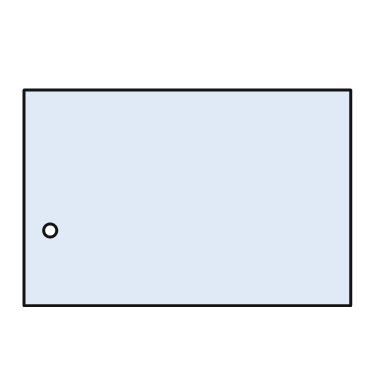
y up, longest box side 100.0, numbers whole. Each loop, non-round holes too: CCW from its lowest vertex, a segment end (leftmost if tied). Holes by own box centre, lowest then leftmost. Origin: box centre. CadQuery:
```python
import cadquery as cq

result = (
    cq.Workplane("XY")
    .moveTo(-50.0, -33.0)
    .lineTo(50.0, -33.0)
    .lineTo(50.0, 33.0)
    .lineTo(-50.0, 33.0)
    .close()
    .moveTo(-42.0, -10.0)
    .circle(2.0)
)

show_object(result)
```